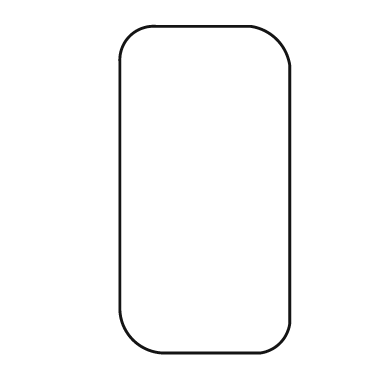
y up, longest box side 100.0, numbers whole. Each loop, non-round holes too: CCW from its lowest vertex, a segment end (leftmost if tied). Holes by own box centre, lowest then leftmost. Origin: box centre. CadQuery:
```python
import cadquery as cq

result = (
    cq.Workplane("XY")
    .moveTo(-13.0, -50.0)
    .lineTo(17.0, -50.0)
    .threePointArc((23.0, -47.0), (26.0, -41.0))
    .lineTo(26.0, 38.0)
    .threePointArc((22.0, 46.0), (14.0, 50.0))
    .lineTo(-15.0, 50.0)
    .threePointArc((-23.0, 47.0), (-26.0, 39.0))
    .lineTo(-26.0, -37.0)
    .threePointArc((-22.0, -46.0), (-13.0, -50.0))
    .close()
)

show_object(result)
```